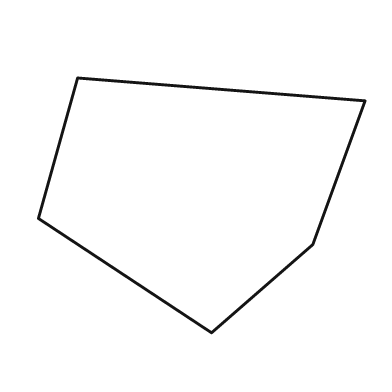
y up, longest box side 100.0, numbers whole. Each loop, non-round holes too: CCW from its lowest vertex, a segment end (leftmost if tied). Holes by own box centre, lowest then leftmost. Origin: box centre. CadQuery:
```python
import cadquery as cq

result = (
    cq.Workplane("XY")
    .moveTo(3.0, -39.0)
    .lineTo(34.0, -12.0)
    .lineTo(50.0, 32.0)
    .lineTo(-38.0, 39.0)
    .lineTo(-50.0, -4.0)
    .close()
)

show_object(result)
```